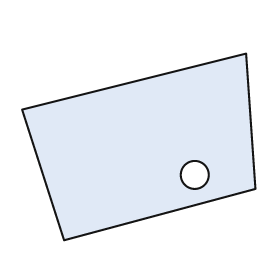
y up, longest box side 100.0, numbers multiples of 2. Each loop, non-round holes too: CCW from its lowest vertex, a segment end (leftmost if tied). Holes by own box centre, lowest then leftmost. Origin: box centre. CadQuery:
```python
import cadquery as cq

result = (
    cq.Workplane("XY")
    .moveTo(-32.0, -40.0)
    .lineTo(50.0, -18.0)
    .lineTo(46.0, 40.0)
    .lineTo(-50.0, 16.0)
    .close()
    .moveTo(24.0, -12.0)
    .circle(6.0)
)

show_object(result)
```